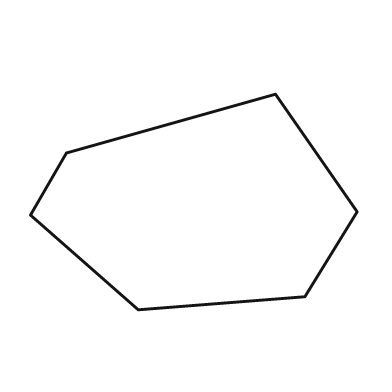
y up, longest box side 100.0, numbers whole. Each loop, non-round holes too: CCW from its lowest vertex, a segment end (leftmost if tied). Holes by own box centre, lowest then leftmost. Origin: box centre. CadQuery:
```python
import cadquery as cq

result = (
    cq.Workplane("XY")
    .moveTo(-17.0, -33.0)
    .lineTo(34.0, -29.0)
    .lineTo(50.0, -3.0)
    .lineTo(25.0, 33.0)
    .lineTo(-39.0, 15.0)
    .lineTo(-50.0, -4.0)
    .close()
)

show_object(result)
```